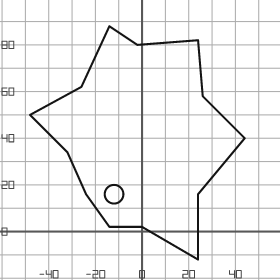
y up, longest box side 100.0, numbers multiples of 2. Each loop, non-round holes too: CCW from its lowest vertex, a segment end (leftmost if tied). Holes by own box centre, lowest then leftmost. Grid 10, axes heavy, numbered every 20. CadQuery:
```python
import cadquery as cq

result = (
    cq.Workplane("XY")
    .moveTo(24.0, -12.0)
    .lineTo(24.0, 16.0)
    .lineTo(44.0, 40.0)
    .lineTo(26.0, 58.0)
    .lineTo(24.0, 82.0)
    .lineTo(-2.0, 80.0)
    .lineTo(-14.0, 88.0)
    .lineTo(-26.0, 62.0)
    .lineTo(-48.0, 50.0)
    .lineTo(-32.0, 34.0)
    .lineTo(-24.0, 16.0)
    .lineTo(-14.0, 2.0)
    .lineTo(0.0, 2.0)
    .close()
    .moveTo(-12.0, 16.0)
    .circle(4.0)
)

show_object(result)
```